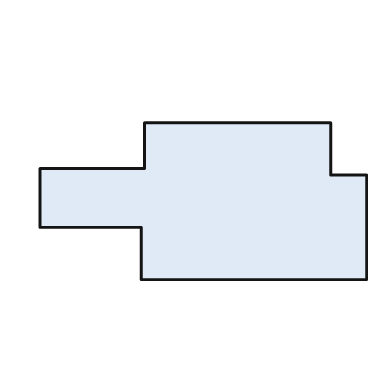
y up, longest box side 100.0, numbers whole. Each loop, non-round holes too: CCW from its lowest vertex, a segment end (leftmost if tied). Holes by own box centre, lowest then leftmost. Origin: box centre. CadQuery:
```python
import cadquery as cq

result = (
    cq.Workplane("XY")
    .moveTo(-19.0, -24.0)
    .lineTo(50.0, -24.0)
    .lineTo(50.0, 8.0)
    .lineTo(39.0, 8.0)
    .lineTo(39.0, 24.0)
    .lineTo(-18.0, 24.0)
    .lineTo(-18.0, 10.0)
    .lineTo(-50.0, 10.0)
    .lineTo(-50.0, -8.0)
    .lineTo(-19.0, -8.0)
    .close()
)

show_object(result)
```